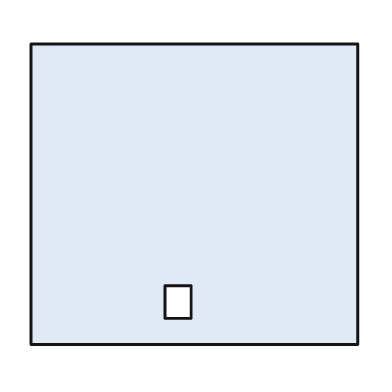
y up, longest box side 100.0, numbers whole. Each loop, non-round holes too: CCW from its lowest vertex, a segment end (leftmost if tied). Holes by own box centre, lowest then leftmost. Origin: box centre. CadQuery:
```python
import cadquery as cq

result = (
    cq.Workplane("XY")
    .moveTo(-50.0, -46.0)
    .lineTo(50.0, -46.0)
    .lineTo(50.0, 46.0)
    .lineTo(-50.0, 46.0)
    .close()
    .moveTo(-9.0, -38.0)
    .lineTo(-1.0, -38.0)
    .lineTo(-1.0, -28.0)
    .lineTo(-9.0, -28.0)
    .close()
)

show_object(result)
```